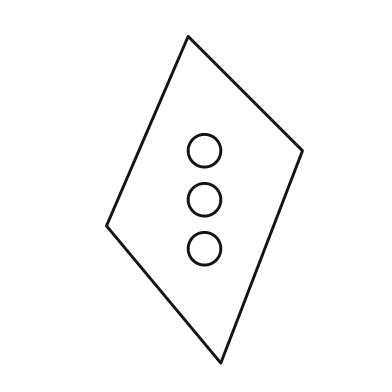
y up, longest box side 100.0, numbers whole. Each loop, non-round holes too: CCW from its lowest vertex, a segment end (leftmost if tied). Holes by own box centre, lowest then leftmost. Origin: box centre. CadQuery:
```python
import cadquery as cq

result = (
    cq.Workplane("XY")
    .moveTo(5.0, -50.0)
    .lineTo(30.0, 15.0)
    .lineTo(-5.0, 50.0)
    .lineTo(-30.0, -8.0)
    .close()
    .moveTo(0.0, -15.0)
    .circle(5.0)
    .moveTo(0.0, 0.0)
    .circle(5.0)
    .moveTo(0.0, 15.0)
    .circle(5.0)
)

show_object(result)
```